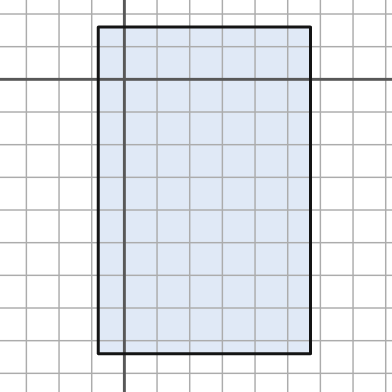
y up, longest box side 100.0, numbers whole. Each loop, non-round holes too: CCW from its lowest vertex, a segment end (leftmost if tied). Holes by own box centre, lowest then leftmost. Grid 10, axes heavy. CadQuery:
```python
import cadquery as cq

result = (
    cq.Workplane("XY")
    .moveTo(-8.0, -84.0)
    .lineTo(57.0, -84.0)
    .lineTo(57.0, 16.0)
    .lineTo(-8.0, 16.0)
    .close()
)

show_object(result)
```